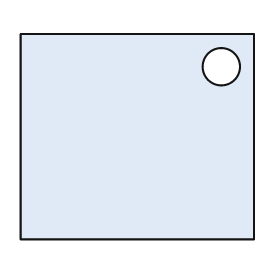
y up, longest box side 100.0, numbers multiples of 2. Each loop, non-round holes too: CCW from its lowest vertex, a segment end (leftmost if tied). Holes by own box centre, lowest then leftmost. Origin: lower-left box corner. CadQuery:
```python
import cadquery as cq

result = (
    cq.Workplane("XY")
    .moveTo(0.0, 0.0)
    .lineTo(100.0, 0.0)
    .lineTo(100.0, 88.0)
    .lineTo(0.0, 88.0)
    .close()
    .moveTo(86.0, 74.0)
    .circle(8.0)
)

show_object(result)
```